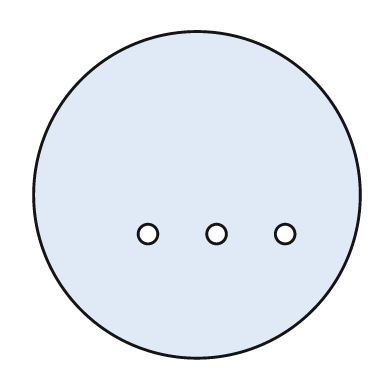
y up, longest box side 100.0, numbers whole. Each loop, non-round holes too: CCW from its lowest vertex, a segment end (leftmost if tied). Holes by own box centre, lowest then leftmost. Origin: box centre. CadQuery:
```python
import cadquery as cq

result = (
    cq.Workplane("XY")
    .moveTo(0.0, 0.0)
    .circle(50.0)
    .moveTo(-15.0, -12.0)
    .circle(3.0)
    .moveTo(6.0, -12.0)
    .circle(3.0)
    .moveTo(27.0, -12.0)
    .circle(3.0)
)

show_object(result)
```